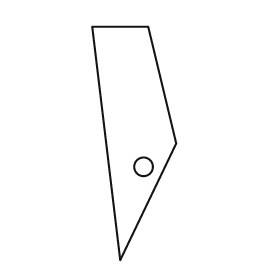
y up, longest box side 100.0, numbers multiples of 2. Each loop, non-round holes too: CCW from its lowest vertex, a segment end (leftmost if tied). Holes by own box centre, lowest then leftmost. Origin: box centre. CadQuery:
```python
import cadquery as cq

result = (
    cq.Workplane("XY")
    .moveTo(-6.0, -50.0)
    .lineTo(18.0, 0.0)
    .lineTo(6.0, 50.0)
    .lineTo(-18.0, 50.0)
    .close()
    .moveTo(4.0, -10.0)
    .circle(4.0)
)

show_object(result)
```